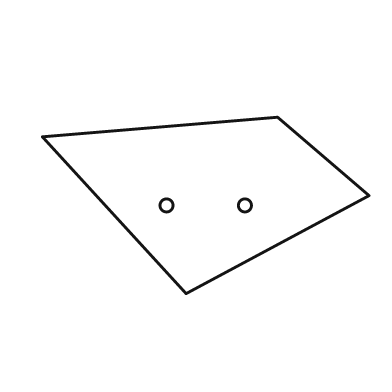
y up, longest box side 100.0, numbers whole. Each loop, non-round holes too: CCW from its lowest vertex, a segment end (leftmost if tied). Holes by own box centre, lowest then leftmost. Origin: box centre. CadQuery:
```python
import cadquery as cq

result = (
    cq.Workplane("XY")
    .moveTo(-6.0, -27.0)
    .lineTo(50.0, 3.0)
    .lineTo(22.0, 27.0)
    .lineTo(-50.0, 21.0)
    .close()
    .moveTo(-12.0, 0.0)
    .circle(2.0)
    .moveTo(12.0, 0.0)
    .circle(2.0)
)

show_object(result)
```